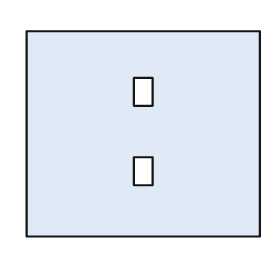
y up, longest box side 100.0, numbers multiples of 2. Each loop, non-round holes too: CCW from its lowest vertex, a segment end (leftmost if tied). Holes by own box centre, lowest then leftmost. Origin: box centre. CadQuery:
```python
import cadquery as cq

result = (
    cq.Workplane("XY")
    .moveTo(-50.0, -44.0)
    .lineTo(50.0, -44.0)
    .lineTo(50.0, 44.0)
    .lineTo(-50.0, 44.0)
    .close()
    .moveTo(-4.0, -22.0)
    .lineTo(4.0, -22.0)
    .lineTo(4.0, -10.0)
    .lineTo(-4.0, -10.0)
    .close()
    .moveTo(-4.0, 12.0)
    .lineTo(4.0, 12.0)
    .lineTo(4.0, 24.0)
    .lineTo(-4.0, 24.0)
    .close()
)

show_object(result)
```